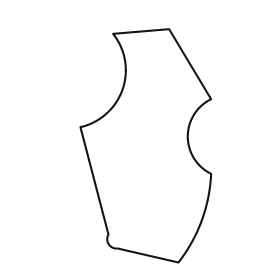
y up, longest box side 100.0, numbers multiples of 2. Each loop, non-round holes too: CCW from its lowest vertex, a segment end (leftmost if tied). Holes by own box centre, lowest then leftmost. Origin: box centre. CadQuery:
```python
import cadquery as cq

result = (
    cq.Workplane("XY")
    .moveTo(14.0, -50.0)
    .threePointArc((24.0, -32.0), (28.0, -12.0))
    .threePointArc((18.0, 4.0), (28.0, 20.0))
    .lineTo(10.0, 50.0)
    .lineTo(-14.0, 48.0)
    .threePointArc((-10.0, 24.0), (-28.0, 8.0))
    .lineTo(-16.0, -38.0)
    .threePointArc((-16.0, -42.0), (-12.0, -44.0))
    .close()
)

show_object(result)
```